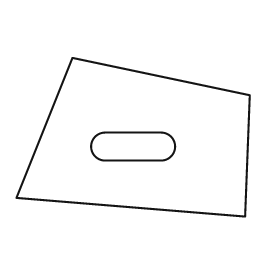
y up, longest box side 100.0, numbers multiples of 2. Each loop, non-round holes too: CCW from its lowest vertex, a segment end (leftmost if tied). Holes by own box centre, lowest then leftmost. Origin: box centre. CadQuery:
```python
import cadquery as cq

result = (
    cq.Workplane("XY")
    .moveTo(48.0, -34.0)
    .lineTo(50.0, 18.0)
    .lineTo(-26.0, 34.0)
    .lineTo(-50.0, -26.0)
    .close()
    .moveTo(-12.0, -10.0)
    .lineTo(12.0, -10.0)
    .threePointArc((18.0, -4.0), (12.0, 2.0))
    .lineTo(-12.0, 2.0)
    .threePointArc((-18.0, -4.0), (-12.0, -10.0))
    .close()
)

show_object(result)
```